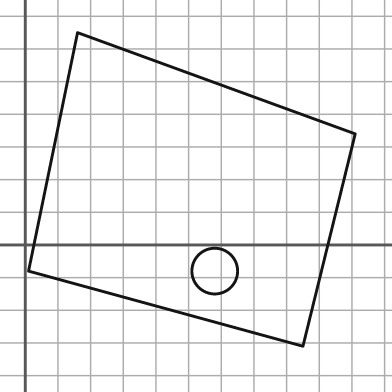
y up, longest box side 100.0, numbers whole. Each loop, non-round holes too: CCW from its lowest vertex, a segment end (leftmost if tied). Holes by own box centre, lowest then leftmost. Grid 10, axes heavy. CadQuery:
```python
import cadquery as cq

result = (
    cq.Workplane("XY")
    .moveTo(85.0, -31.0)
    .lineTo(101.0, 34.0)
    .lineTo(16.0, 65.0)
    .lineTo(1.0, -8.0)
    .close()
    .moveTo(58.0, -8.0)
    .circle(7.0)
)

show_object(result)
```